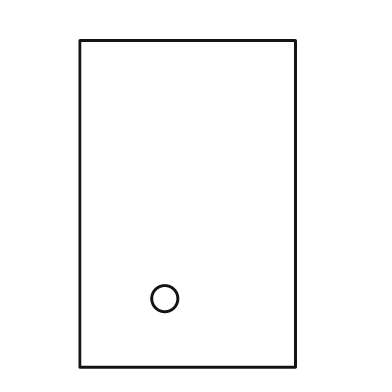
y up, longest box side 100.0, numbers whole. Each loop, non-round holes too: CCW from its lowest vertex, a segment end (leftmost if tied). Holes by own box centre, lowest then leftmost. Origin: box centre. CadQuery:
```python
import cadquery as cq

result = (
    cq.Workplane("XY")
    .moveTo(-33.0, -50.0)
    .lineTo(33.0, -50.0)
    .lineTo(33.0, 50.0)
    .lineTo(-33.0, 50.0)
    .close()
    .moveTo(-7.0, -29.0)
    .circle(4.0)
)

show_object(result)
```